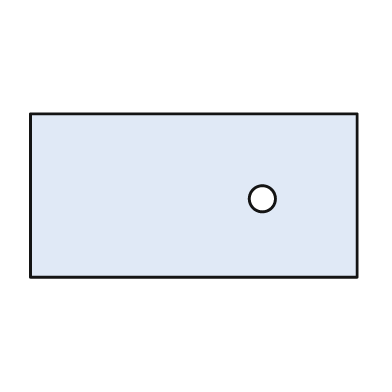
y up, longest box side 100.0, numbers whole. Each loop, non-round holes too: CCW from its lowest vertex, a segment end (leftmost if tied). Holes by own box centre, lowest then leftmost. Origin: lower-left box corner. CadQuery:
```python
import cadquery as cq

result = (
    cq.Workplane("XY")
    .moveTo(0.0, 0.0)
    .lineTo(100.0, 0.0)
    .lineTo(100.0, 50.0)
    .lineTo(0.0, 50.0)
    .close()
    .moveTo(71.0, 24.0)
    .circle(4.0)
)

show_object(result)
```